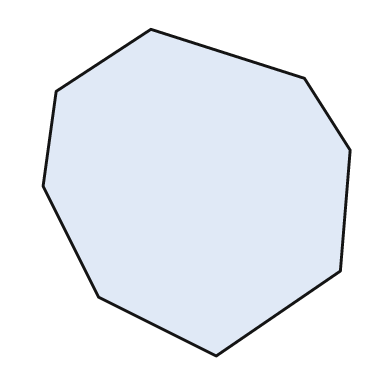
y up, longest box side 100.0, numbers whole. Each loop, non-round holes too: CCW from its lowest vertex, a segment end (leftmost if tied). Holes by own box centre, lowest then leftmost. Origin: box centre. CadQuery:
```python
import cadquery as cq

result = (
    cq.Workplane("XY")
    .moveTo(6.0, -50.0)
    .lineTo(44.0, -24.0)
    .lineTo(47.0, 13.0)
    .lineTo(33.0, 35.0)
    .lineTo(-14.0, 50.0)
    .lineTo(-43.0, 31.0)
    .lineTo(-47.0, 2.0)
    .lineTo(-30.0, -32.0)
    .close()
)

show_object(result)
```